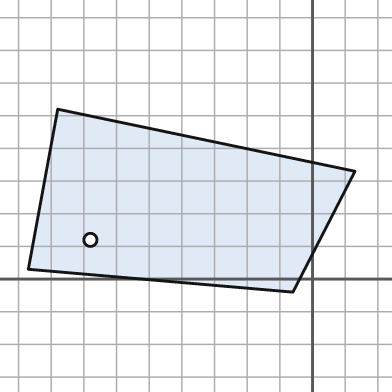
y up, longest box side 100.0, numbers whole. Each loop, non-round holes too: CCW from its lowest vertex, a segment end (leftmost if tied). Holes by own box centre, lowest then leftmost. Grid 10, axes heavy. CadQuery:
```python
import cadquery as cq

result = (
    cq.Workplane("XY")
    .moveTo(-6.0, -4.0)
    .lineTo(13.0, 33.0)
    .lineTo(-78.0, 52.0)
    .lineTo(-87.0, 3.0)
    .close()
    .moveTo(-68.0, 12.0)
    .circle(2.0)
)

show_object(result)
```